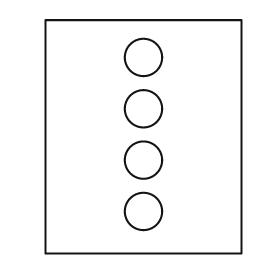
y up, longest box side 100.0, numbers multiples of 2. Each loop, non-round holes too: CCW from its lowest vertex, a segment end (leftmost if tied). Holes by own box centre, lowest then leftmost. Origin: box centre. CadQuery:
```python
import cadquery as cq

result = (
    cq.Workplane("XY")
    .moveTo(-42.0, -50.0)
    .lineTo(42.0, -50.0)
    .lineTo(42.0, 50.0)
    .lineTo(-42.0, 50.0)
    .close()
    .moveTo(0.0, -32.0)
    .circle(8.0)
    .moveTo(0.0, -10.0)
    .circle(8.0)
    .moveTo(0.0, 12.0)
    .circle(8.0)
    .moveTo(0.0, 34.0)
    .circle(8.0)
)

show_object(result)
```